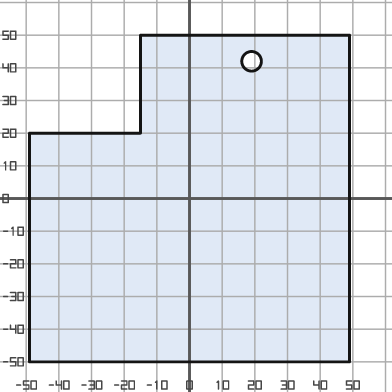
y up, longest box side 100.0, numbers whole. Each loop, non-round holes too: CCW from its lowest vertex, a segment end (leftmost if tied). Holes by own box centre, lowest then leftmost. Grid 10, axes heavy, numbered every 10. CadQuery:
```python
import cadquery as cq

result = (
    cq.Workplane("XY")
    .moveTo(-49.0, -50.0)
    .lineTo(49.0, -50.0)
    .lineTo(49.0, 50.0)
    .lineTo(-15.0, 50.0)
    .lineTo(-15.0, 20.0)
    .lineTo(-49.0, 20.0)
    .close()
    .moveTo(19.0, 42.0)
    .circle(3.0)
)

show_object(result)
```